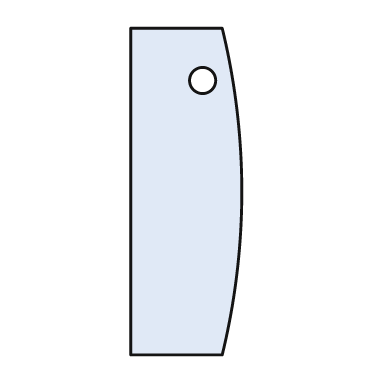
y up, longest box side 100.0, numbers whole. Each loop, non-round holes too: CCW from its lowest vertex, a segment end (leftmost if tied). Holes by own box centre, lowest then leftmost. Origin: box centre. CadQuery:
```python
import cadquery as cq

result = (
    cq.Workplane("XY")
    .moveTo(-17.0, -50.0)
    .lineTo(11.0, -50.0)
    .threePointArc((17.0, 0.0), (11.0, 50.0))
    .lineTo(-17.0, 50.0)
    .close()
    .moveTo(5.0, 34.0)
    .circle(4.0)
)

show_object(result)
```